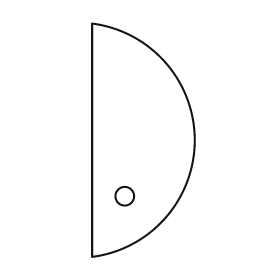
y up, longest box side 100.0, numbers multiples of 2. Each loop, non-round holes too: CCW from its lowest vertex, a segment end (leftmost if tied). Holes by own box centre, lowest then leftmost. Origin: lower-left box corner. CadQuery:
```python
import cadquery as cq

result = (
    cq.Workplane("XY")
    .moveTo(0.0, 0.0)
    .threePointArc((44.0, 50.0), (0.0, 100.0))
    .close()
    .moveTo(14.0, 26.0)
    .circle(4.0)
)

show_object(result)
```